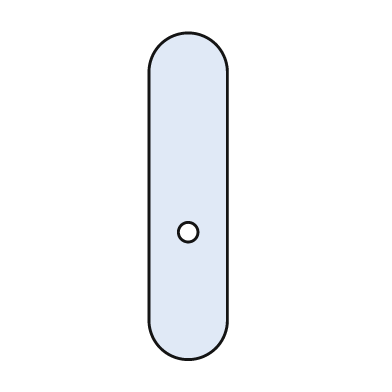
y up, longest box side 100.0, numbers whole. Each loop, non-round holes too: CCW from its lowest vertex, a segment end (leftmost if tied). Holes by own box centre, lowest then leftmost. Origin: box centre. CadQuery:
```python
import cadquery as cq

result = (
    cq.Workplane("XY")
    .moveTo(-12.0, -38.0)
    .threePointArc((0.0, -50.0), (12.0, -38.0))
    .lineTo(12.0, 38.0)
    .threePointArc((0.0, 50.0), (-12.0, 38.0))
    .close()
    .moveTo(0.0, -11.0)
    .circle(3.0)
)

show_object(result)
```